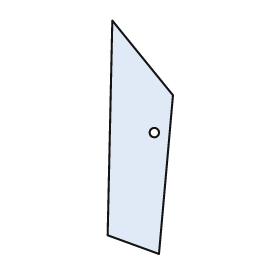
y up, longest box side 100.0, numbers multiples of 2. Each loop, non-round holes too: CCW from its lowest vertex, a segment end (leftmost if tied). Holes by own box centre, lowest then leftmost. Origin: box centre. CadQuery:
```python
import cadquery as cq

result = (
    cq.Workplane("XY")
    .moveTo(8.0, -50.0)
    .lineTo(14.0, 18.0)
    .lineTo(-12.0, 50.0)
    .lineTo(-14.0, -42.0)
    .close()
    .moveTo(6.0, 2.0)
    .circle(2.0)
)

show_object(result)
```